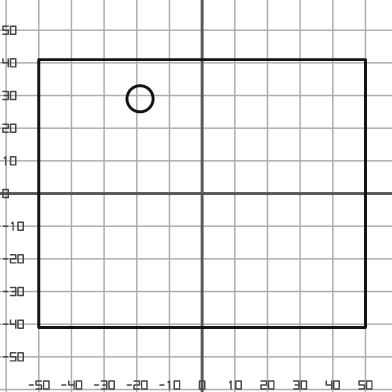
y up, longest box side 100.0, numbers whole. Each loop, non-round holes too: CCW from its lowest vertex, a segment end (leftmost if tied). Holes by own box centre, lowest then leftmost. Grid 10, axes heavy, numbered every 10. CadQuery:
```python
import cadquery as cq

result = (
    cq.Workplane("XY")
    .moveTo(-50.0, -41.0)
    .lineTo(50.0, -41.0)
    .lineTo(50.0, 41.0)
    .lineTo(-50.0, 41.0)
    .close()
    .moveTo(-19.0, 29.0)
    .circle(4.0)
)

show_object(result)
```